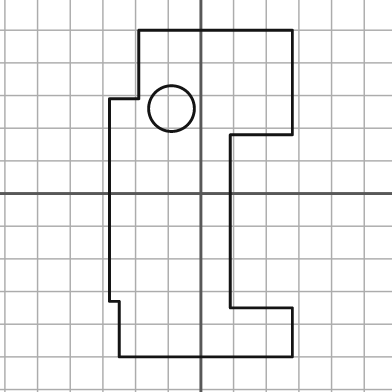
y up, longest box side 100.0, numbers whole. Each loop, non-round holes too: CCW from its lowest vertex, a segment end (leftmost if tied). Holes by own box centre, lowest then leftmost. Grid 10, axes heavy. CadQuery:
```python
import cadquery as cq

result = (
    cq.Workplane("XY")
    .moveTo(-25.0, -50.0)
    .lineTo(28.0, -50.0)
    .lineTo(28.0, -35.0)
    .lineTo(9.0, -35.0)
    .lineTo(9.0, 18.0)
    .lineTo(28.0, 18.0)
    .lineTo(28.0, 50.0)
    .lineTo(-19.0, 50.0)
    .lineTo(-19.0, 29.0)
    .lineTo(-28.0, 29.0)
    .lineTo(-28.0, -33.0)
    .lineTo(-25.0, -33.0)
    .close()
    .moveTo(-9.0, 26.0)
    .circle(7.0)
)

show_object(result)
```